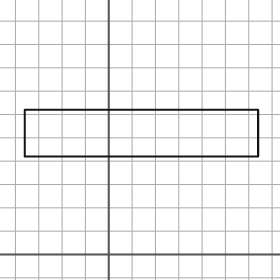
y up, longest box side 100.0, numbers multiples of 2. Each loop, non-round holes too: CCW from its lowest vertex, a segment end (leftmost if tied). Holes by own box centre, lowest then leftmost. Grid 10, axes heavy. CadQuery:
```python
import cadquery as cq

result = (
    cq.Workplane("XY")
    .moveTo(-36.0, 42.0)
    .lineTo(64.0, 42.0)
    .lineTo(64.0, 62.0)
    .lineTo(-36.0, 62.0)
    .close()
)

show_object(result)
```